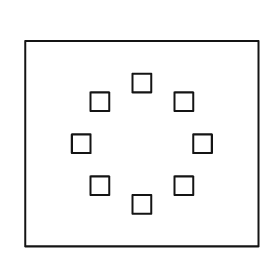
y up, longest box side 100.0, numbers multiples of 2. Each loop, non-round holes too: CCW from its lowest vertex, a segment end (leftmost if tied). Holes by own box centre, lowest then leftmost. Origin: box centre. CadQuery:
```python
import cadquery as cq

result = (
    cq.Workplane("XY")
    .moveTo(-50.0, -44.0)
    .lineTo(50.0, -44.0)
    .lineTo(50.0, 44.0)
    .lineTo(-50.0, 44.0)
    .close()
    .moveTo(-4.0, -30.0)
    .lineTo(4.0, -30.0)
    .lineTo(4.0, -22.0)
    .lineTo(-4.0, -22.0)
    .close()
    .moveTo(-22.0, -22.0)
    .lineTo(-14.0, -22.0)
    .lineTo(-14.0, -14.0)
    .lineTo(-22.0, -14.0)
    .close()
    .moveTo(14.0, -22.0)
    .lineTo(22.0, -22.0)
    .lineTo(22.0, -14.0)
    .lineTo(14.0, -14.0)
    .close()
    .moveTo(-30.0, -4.0)
    .lineTo(-22.0, -4.0)
    .lineTo(-22.0, 4.0)
    .lineTo(-30.0, 4.0)
    .close()
    .moveTo(22.0, -4.0)
    .lineTo(30.0, -4.0)
    .lineTo(30.0, 4.0)
    .lineTo(22.0, 4.0)
    .close()
    .moveTo(-22.0, 14.0)
    .lineTo(-14.0, 14.0)
    .lineTo(-14.0, 22.0)
    .lineTo(-22.0, 22.0)
    .close()
    .moveTo(14.0, 14.0)
    .lineTo(22.0, 14.0)
    .lineTo(22.0, 22.0)
    .lineTo(14.0, 22.0)
    .close()
    .moveTo(-4.0, 22.0)
    .lineTo(4.0, 22.0)
    .lineTo(4.0, 30.0)
    .lineTo(-4.0, 30.0)
    .close()
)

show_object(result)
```